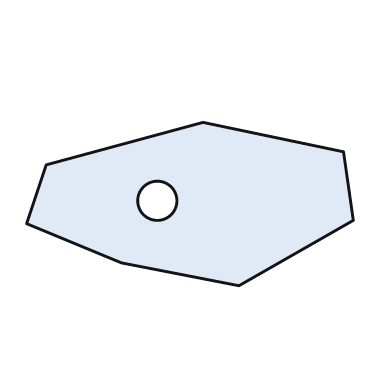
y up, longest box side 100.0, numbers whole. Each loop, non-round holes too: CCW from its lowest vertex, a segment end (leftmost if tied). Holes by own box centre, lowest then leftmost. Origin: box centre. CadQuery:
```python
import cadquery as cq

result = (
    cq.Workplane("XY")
    .moveTo(15.0, -25.0)
    .lineTo(50.0, -5.0)
    .lineTo(47.0, 16.0)
    .lineTo(4.0, 25.0)
    .lineTo(-44.0, 12.0)
    .lineTo(-50.0, -6.0)
    .lineTo(-21.0, -18.0)
    .close()
    .moveTo(-10.0, 1.0)
    .circle(6.0)
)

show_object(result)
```